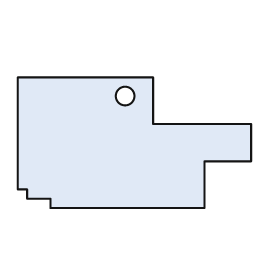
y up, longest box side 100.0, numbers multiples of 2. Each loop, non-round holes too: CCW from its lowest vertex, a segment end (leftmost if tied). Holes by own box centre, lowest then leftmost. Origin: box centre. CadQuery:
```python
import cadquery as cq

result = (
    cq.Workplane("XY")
    .moveTo(-36.0, -28.0)
    .lineTo(30.0, -28.0)
    .lineTo(30.0, -8.0)
    .lineTo(50.0, -8.0)
    .lineTo(50.0, 8.0)
    .lineTo(8.0, 8.0)
    .lineTo(8.0, 28.0)
    .lineTo(-50.0, 28.0)
    .lineTo(-50.0, -20.0)
    .lineTo(-46.0, -20.0)
    .lineTo(-46.0, -24.0)
    .lineTo(-36.0, -24.0)
    .close()
    .moveTo(-4.0, 20.0)
    .circle(4.0)
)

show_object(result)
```